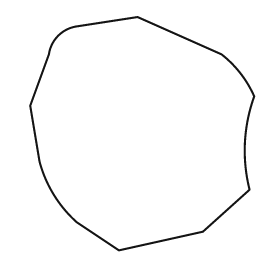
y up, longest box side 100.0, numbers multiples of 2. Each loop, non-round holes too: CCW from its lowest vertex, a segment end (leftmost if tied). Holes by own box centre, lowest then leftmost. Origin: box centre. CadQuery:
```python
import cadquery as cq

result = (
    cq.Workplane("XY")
    .moveTo(-10.0, -50.0)
    .lineTo(26.0, -42.0)
    .lineTo(46.0, -24.0)
    .threePointArc((44.0, -4.0), (48.0, 16.0))
    .threePointArc((42.0, 26.0), (34.0, 34.0))
    .lineTo(-2.0, 50.0)
    .lineTo(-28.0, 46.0)
    .threePointArc((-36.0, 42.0), (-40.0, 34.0))
    .lineTo(-48.0, 12.0)
    .lineTo(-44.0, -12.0)
    .threePointArc((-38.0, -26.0), (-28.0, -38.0))
    .close()
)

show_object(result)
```